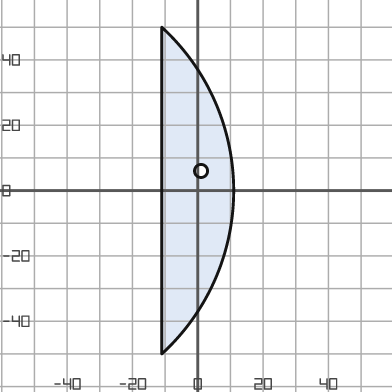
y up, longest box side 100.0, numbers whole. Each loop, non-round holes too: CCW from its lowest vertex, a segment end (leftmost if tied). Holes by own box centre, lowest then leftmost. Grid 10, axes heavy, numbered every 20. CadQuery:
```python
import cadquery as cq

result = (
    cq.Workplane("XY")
    .moveTo(-11.0, -50.0)
    .threePointArc((11.0, 0.0), (-11.0, 50.0))
    .close()
    .moveTo(1.0, 6.0)
    .circle(2.0)
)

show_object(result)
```